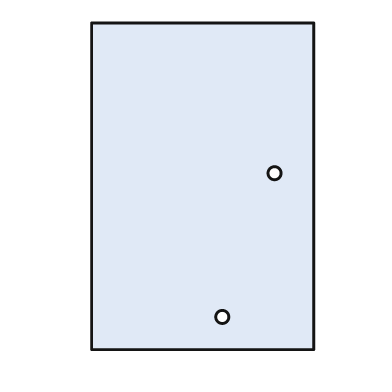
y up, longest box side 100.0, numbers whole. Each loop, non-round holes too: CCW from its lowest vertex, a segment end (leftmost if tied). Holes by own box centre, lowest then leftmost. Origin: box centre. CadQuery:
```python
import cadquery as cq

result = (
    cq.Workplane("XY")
    .moveTo(-34.0, -50.0)
    .lineTo(34.0, -50.0)
    .lineTo(34.0, 50.0)
    .lineTo(-34.0, 50.0)
    .close()
    .moveTo(6.0, -40.0)
    .circle(2.0)
    .moveTo(22.0, 4.0)
    .circle(2.0)
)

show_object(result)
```